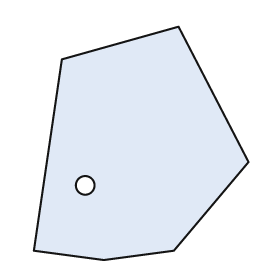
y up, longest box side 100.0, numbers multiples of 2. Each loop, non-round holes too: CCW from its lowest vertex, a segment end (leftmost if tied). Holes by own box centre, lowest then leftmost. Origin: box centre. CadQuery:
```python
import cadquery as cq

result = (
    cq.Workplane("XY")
    .moveTo(-16.0, -50.0)
    .lineTo(14.0, -46.0)
    .lineTo(46.0, -8.0)
    .lineTo(16.0, 50.0)
    .lineTo(-34.0, 36.0)
    .lineTo(-46.0, -46.0)
    .close()
    .moveTo(-24.0, -18.0)
    .circle(4.0)
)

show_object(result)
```